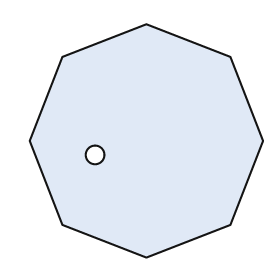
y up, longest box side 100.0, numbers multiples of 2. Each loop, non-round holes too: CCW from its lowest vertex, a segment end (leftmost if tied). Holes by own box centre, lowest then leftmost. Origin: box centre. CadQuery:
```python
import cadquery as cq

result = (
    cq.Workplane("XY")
    .moveTo(0.0, -50.0)
    .lineTo(36.0, -36.0)
    .lineTo(50.0, 0.0)
    .lineTo(36.0, 36.0)
    .lineTo(0.0, 50.0)
    .lineTo(-36.0, 36.0)
    .lineTo(-50.0, 0.0)
    .lineTo(-36.0, -36.0)
    .close()
    .moveTo(-22.0, -6.0)
    .circle(4.0)
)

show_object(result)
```